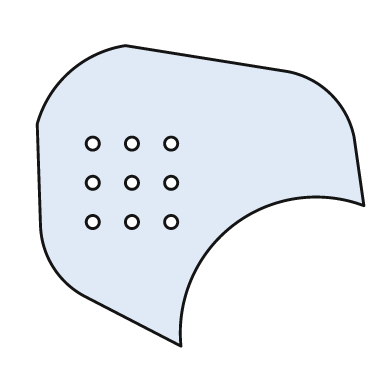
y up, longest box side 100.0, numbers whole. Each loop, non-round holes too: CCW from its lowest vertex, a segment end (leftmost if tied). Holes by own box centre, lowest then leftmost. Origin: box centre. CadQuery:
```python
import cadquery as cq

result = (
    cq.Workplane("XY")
    .moveTo(-6.0, -46.0)
    .threePointArc((10.0, -9.0), (50.0, -3.0))
    .lineTo(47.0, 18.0)
    .threePointArc((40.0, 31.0), (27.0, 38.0))
    .lineTo(-23.0, 46.0)
    .threePointArc((-40.0, 38.0), (-50.0, 22.0))
    .lineTo(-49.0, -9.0)
    .threePointArc((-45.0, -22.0), (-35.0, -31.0))
    .close()
    .moveTo(-33.0, -8.0)
    .circle(2.0)
    .moveTo(-21.0, -8.0)
    .circle(2.0)
    .moveTo(-9.0, -8.0)
    .circle(2.0)
    .moveTo(-33.0, 4.0)
    .circle(2.0)
    .moveTo(-21.0, 4.0)
    .circle(2.0)
    .moveTo(-9.0, 4.0)
    .circle(2.0)
    .moveTo(-33.0, 16.0)
    .circle(2.0)
    .moveTo(-21.0, 16.0)
    .circle(2.0)
    .moveTo(-9.0, 16.0)
    .circle(2.0)
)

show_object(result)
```